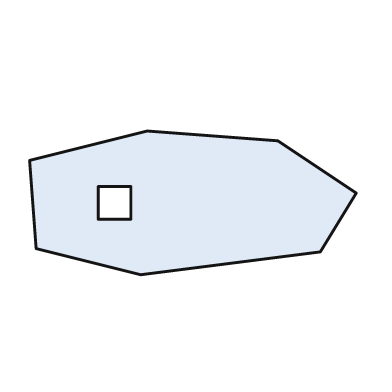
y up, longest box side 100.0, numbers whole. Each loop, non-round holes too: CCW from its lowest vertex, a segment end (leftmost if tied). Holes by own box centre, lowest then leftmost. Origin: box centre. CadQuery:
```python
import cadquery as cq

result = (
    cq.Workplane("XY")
    .moveTo(-16.0, -22.0)
    .lineTo(39.0, -15.0)
    .lineTo(50.0, 3.0)
    .lineTo(26.0, 19.0)
    .lineTo(-14.0, 22.0)
    .lineTo(-50.0, 13.0)
    .lineTo(-48.0, -14.0)
    .close()
    .moveTo(-29.0, -5.0)
    .lineTo(-19.0, -5.0)
    .lineTo(-19.0, 5.0)
    .lineTo(-29.0, 5.0)
    .close()
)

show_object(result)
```